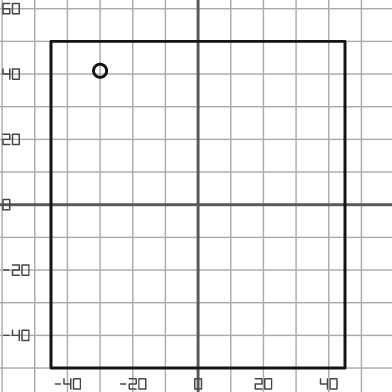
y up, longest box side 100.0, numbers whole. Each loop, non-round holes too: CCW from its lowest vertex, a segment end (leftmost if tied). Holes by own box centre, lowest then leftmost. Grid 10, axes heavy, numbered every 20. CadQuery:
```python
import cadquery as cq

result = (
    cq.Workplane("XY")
    .moveTo(-45.0, -50.0)
    .lineTo(45.0, -50.0)
    .lineTo(45.0, 50.0)
    .lineTo(-45.0, 50.0)
    .close()
    .moveTo(-30.0, 41.0)
    .circle(2.0)
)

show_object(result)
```